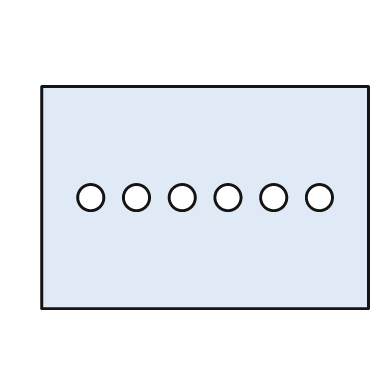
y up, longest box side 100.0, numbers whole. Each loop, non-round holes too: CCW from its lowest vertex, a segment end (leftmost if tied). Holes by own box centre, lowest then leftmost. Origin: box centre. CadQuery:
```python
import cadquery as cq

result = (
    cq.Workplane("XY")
    .moveTo(-50.0, -34.0)
    .lineTo(50.0, -34.0)
    .lineTo(50.0, 34.0)
    .lineTo(-50.0, 34.0)
    .close()
    .moveTo(-35.0, 0.0)
    .circle(4.0)
    .moveTo(-21.0, 0.0)
    .circle(4.0)
    .moveTo(-7.0, 0.0)
    .circle(4.0)
    .moveTo(7.0, 0.0)
    .circle(4.0)
    .moveTo(21.0, 0.0)
    .circle(4.0)
    .moveTo(35.0, 0.0)
    .circle(4.0)
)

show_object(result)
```